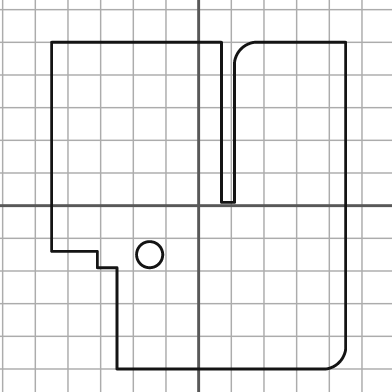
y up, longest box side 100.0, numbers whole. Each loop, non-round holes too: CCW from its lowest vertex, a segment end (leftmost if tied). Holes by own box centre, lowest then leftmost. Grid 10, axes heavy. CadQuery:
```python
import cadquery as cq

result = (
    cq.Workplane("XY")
    .moveTo(-25.0, -50.0)
    .lineTo(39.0, -50.0)
    .threePointArc((43.0, -48.0), (45.0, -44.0))
    .lineTo(45.0, 50.0)
    .lineTo(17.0, 50.0)
    .threePointArc((13.0, 48.0), (11.0, 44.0))
    .lineTo(11.0, 1.0)
    .lineTo(7.0, 1.0)
    .lineTo(7.0, 50.0)
    .lineTo(-45.0, 50.0)
    .lineTo(-45.0, -14.0)
    .lineTo(-31.0, -14.0)
    .lineTo(-31.0, -19.0)
    .lineTo(-25.0, -19.0)
    .close()
    .moveTo(-15.0, -15.0)
    .circle(4.0)
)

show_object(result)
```